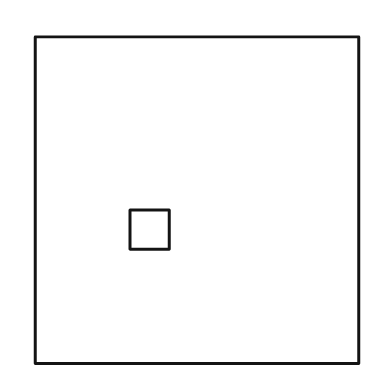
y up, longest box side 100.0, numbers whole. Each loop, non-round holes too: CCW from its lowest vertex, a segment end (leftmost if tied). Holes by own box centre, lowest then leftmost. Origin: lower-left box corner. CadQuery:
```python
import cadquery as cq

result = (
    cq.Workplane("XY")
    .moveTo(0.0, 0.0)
    .lineTo(99.0, 0.0)
    .lineTo(99.0, 100.0)
    .lineTo(0.0, 100.0)
    .close()
    .moveTo(29.0, 35.0)
    .lineTo(41.0, 35.0)
    .lineTo(41.0, 47.0)
    .lineTo(29.0, 47.0)
    .close()
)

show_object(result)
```